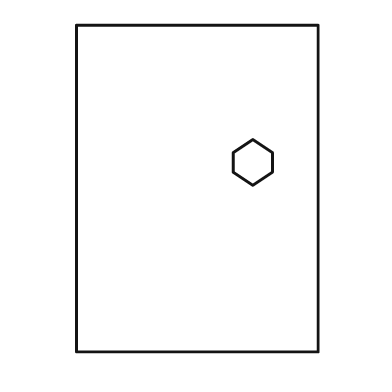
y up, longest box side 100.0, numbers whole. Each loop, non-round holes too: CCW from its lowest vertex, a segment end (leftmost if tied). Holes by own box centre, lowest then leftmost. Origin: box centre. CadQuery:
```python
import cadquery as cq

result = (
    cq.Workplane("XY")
    .moveTo(-37.0, -50.0)
    .lineTo(37.0, -50.0)
    .lineTo(37.0, 50.0)
    .lineTo(-37.0, 50.0)
    .close()
    .moveTo(17.0, 1.0)
    .lineTo(23.0, 5.0)
    .lineTo(23.0, 11.0)
    .lineTo(17.0, 15.0)
    .lineTo(11.0, 11.0)
    .lineTo(11.0, 5.0)
    .close()
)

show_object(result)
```